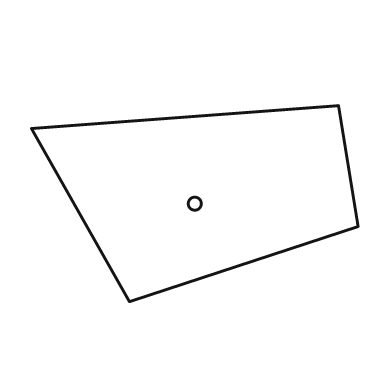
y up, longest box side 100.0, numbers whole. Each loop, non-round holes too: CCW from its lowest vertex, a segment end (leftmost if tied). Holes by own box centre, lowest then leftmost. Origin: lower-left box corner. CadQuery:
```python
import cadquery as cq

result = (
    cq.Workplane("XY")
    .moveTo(30.0, 0.0)
    .lineTo(100.0, 23.0)
    .lineTo(94.0, 60.0)
    .lineTo(0.0, 53.0)
    .close()
    .moveTo(50.0, 30.0)
    .circle(2.0)
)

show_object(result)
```